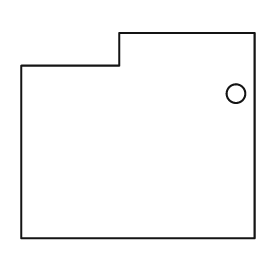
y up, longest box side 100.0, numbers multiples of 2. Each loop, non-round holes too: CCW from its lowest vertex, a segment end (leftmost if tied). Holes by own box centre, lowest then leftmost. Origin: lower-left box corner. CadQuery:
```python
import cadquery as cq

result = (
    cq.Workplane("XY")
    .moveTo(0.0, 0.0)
    .lineTo(100.0, 0.0)
    .lineTo(100.0, 88.0)
    .lineTo(42.0, 88.0)
    .lineTo(42.0, 74.0)
    .lineTo(0.0, 74.0)
    .close()
    .moveTo(92.0, 62.0)
    .circle(4.0)
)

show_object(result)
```